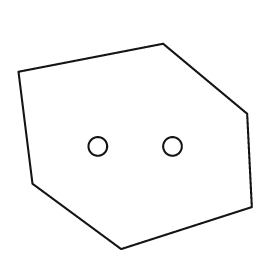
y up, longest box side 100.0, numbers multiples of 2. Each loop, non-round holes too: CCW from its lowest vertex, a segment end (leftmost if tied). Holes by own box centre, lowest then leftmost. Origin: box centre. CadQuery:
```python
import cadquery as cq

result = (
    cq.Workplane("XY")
    .moveTo(-6.0, -44.0)
    .lineTo(50.0, -26.0)
    .lineTo(48.0, 14.0)
    .lineTo(12.0, 44.0)
    .lineTo(-50.0, 32.0)
    .lineTo(-44.0, -16.0)
    .close()
    .moveTo(-16.0, 0.0)
    .circle(4.0)
    .moveTo(16.0, 0.0)
    .circle(4.0)
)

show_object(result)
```